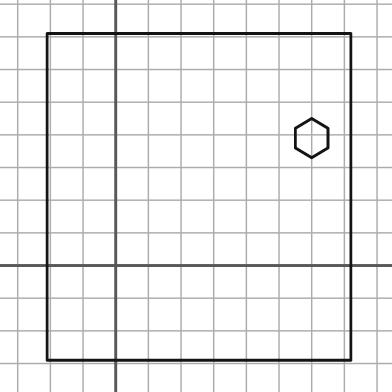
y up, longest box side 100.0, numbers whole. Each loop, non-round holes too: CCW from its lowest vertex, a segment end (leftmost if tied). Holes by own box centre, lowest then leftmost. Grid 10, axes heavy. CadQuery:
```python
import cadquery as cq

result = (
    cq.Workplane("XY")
    .moveTo(-21.0, -29.0)
    .lineTo(72.0, -29.0)
    .lineTo(72.0, 71.0)
    .lineTo(-21.0, 71.0)
    .close()
    .moveTo(60.0, 33.0)
    .lineTo(65.0, 36.0)
    .lineTo(65.0, 42.0)
    .lineTo(60.0, 45.0)
    .lineTo(55.0, 42.0)
    .lineTo(55.0, 36.0)
    .close()
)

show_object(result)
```